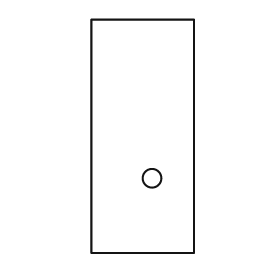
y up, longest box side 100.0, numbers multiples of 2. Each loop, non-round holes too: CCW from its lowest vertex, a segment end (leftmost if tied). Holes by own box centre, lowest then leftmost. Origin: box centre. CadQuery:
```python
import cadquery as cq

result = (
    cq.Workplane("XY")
    .moveTo(-22.0, -50.0)
    .lineTo(22.0, -50.0)
    .lineTo(22.0, 50.0)
    .lineTo(-22.0, 50.0)
    .close()
    .moveTo(4.0, -18.0)
    .circle(4.0)
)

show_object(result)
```